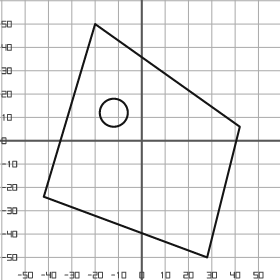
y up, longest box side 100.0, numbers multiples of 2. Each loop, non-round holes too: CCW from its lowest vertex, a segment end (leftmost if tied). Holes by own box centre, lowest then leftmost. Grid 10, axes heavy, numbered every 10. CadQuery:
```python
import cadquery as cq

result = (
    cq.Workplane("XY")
    .moveTo(28.0, -50.0)
    .lineTo(42.0, 6.0)
    .lineTo(-20.0, 50.0)
    .lineTo(-42.0, -24.0)
    .close()
    .moveTo(-12.0, 12.0)
    .circle(6.0)
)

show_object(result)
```